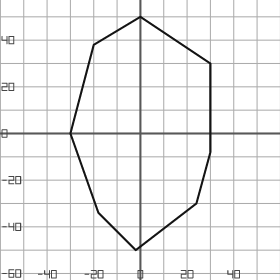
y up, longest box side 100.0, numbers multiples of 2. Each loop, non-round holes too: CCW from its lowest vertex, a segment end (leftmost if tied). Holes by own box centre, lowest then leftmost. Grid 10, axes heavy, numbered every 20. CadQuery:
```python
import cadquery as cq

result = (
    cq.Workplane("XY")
    .moveTo(-2.0, -50.0)
    .lineTo(24.0, -30.0)
    .lineTo(30.0, -8.0)
    .lineTo(30.0, 30.0)
    .lineTo(0.0, 50.0)
    .lineTo(-20.0, 38.0)
    .lineTo(-30.0, 0.0)
    .lineTo(-18.0, -34.0)
    .close()
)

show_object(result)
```